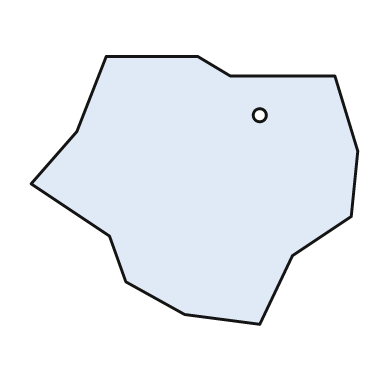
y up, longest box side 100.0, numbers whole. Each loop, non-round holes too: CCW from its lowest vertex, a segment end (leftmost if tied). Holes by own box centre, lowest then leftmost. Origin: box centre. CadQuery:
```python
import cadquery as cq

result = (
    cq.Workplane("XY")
    .moveTo(20.0, -41.0)
    .lineTo(30.0, -20.0)
    .lineTo(48.0, -8.0)
    .lineTo(50.0, 12.0)
    .lineTo(43.0, 35.0)
    .lineTo(11.0, 35.0)
    .lineTo(1.0, 41.0)
    .lineTo(-27.0, 41.0)
    .lineTo(-36.0, 18.0)
    .lineTo(-50.0, 2.0)
    .lineTo(-26.0, -14.0)
    .lineTo(-21.0, -28.0)
    .lineTo(-3.0, -38.0)
    .close()
    .moveTo(20.0, 23.0)
    .circle(2.0)
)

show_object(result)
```